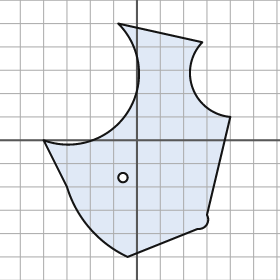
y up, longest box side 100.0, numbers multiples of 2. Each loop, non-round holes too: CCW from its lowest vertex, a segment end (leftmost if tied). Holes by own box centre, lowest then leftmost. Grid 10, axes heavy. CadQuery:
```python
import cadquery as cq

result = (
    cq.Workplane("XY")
    .moveTo(-4.0, -50.0)
    .lineTo(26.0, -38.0)
    .threePointArc((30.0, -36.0), (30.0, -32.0))
    .lineTo(40.0, 10.0)
    .threePointArc((24.0, 22.0), (28.0, 42.0))
    .lineTo(-8.0, 50.0)
    .threePointArc((-4.0, 12.0), (-40.0, 0.0))
    .lineTo(-30.0, -20.0)
    .threePointArc((-20.0, -38.0), (-4.0, -50.0))
    .close()
    .moveTo(-6.0, -16.0)
    .circle(2.0)
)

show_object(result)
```